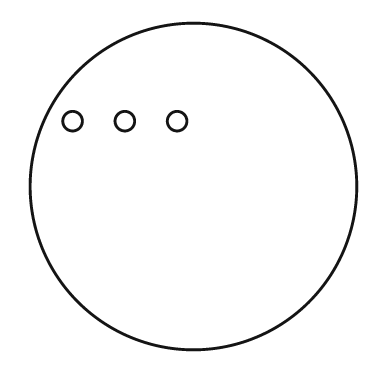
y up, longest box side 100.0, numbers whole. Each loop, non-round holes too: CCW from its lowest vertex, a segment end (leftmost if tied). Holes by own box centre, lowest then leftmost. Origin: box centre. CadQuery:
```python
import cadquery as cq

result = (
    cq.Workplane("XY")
    .moveTo(0.0, 0.0)
    .circle(50.0)
    .moveTo(-37.0, 20.0)
    .circle(3.0)
    .moveTo(-21.0, 20.0)
    .circle(3.0)
    .moveTo(-5.0, 20.0)
    .circle(3.0)
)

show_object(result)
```